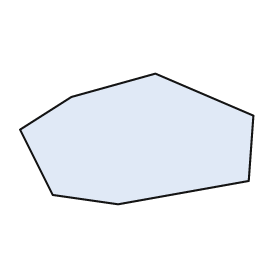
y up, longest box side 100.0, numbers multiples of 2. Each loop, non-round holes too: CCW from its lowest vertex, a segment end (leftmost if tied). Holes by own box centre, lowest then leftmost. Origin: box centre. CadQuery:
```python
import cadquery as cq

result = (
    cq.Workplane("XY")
    .moveTo(-8.0, -28.0)
    .lineTo(48.0, -18.0)
    .lineTo(50.0, 10.0)
    .lineTo(8.0, 28.0)
    .lineTo(-28.0, 18.0)
    .lineTo(-50.0, 4.0)
    .lineTo(-36.0, -24.0)
    .close()
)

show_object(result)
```